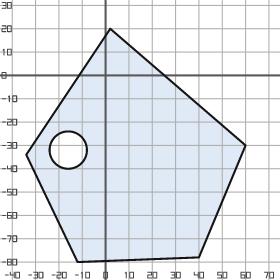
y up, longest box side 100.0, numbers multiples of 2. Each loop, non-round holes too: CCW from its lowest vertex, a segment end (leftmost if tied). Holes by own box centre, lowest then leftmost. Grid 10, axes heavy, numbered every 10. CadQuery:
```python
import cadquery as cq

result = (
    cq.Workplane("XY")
    .moveTo(-12.0, -80.0)
    .lineTo(40.0, -78.0)
    .lineTo(60.0, -30.0)
    .lineTo(2.0, 20.0)
    .lineTo(-34.0, -34.0)
    .close()
    .moveTo(-16.0, -32.0)
    .circle(8.0)
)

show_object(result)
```